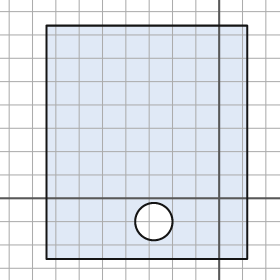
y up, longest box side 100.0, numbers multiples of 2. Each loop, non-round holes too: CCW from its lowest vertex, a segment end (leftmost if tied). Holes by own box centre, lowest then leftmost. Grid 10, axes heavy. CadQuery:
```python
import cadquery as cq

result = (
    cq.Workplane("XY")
    .moveTo(-74.0, -26.0)
    .lineTo(12.0, -26.0)
    .lineTo(12.0, 74.0)
    .lineTo(-74.0, 74.0)
    .close()
    .moveTo(-28.0, -10.0)
    .circle(8.0)
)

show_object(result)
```